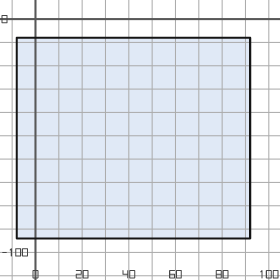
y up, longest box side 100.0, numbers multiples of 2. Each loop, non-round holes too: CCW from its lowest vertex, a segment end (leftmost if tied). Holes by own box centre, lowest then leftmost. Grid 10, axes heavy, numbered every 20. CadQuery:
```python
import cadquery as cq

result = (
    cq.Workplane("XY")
    .moveTo(-8.0, -94.0)
    .lineTo(92.0, -94.0)
    .lineTo(92.0, -8.0)
    .lineTo(-8.0, -8.0)
    .close()
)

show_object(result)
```